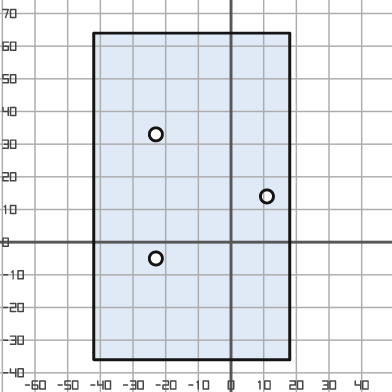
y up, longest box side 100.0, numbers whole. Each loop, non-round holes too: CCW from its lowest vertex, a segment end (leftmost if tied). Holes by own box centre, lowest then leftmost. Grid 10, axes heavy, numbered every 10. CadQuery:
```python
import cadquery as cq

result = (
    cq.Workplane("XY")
    .moveTo(-42.0, -36.0)
    .lineTo(18.0, -36.0)
    .lineTo(18.0, 64.0)
    .lineTo(-42.0, 64.0)
    .close()
    .moveTo(-23.0, -5.0)
    .circle(2.0)
    .moveTo(11.0, 14.0)
    .circle(2.0)
    .moveTo(-23.0, 33.0)
    .circle(2.0)
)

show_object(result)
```